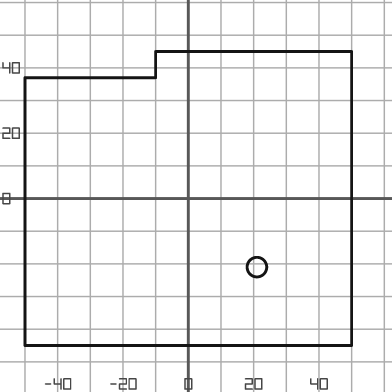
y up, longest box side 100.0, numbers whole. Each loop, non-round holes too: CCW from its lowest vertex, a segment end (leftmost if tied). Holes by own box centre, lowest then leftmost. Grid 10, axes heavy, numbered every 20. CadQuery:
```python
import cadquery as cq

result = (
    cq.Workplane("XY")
    .moveTo(-50.0, -45.0)
    .lineTo(50.0, -45.0)
    .lineTo(50.0, 45.0)
    .lineTo(-10.0, 45.0)
    .lineTo(-10.0, 37.0)
    .lineTo(-50.0, 37.0)
    .close()
    .moveTo(21.0, -21.0)
    .circle(3.0)
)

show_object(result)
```